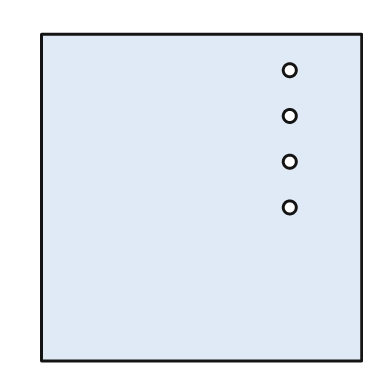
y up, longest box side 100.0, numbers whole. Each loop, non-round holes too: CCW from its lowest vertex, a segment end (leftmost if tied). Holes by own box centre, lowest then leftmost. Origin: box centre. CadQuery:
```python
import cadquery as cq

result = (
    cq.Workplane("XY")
    .moveTo(-49.0, -50.0)
    .lineTo(49.0, -50.0)
    .lineTo(49.0, 50.0)
    .lineTo(-49.0, 50.0)
    .close()
    .moveTo(27.0, -3.0)
    .circle(2.0)
    .moveTo(27.0, 11.0)
    .circle(2.0)
    .moveTo(27.0, 25.0)
    .circle(2.0)
    .moveTo(27.0, 39.0)
    .circle(2.0)
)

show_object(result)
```